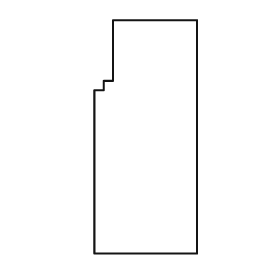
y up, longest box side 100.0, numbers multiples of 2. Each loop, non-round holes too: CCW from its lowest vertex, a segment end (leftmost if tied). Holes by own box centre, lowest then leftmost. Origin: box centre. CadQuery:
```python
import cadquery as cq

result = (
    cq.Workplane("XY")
    .moveTo(-22.0, -50.0)
    .lineTo(22.0, -50.0)
    .lineTo(22.0, 50.0)
    .lineTo(-14.0, 50.0)
    .lineTo(-14.0, 24.0)
    .lineTo(-18.0, 24.0)
    .lineTo(-18.0, 20.0)
    .lineTo(-22.0, 20.0)
    .close()
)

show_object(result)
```